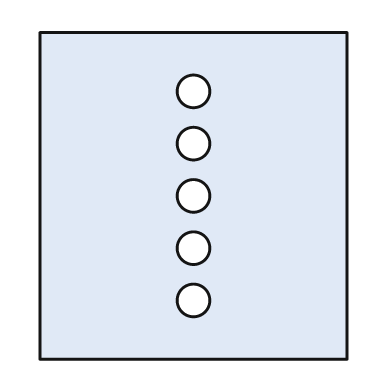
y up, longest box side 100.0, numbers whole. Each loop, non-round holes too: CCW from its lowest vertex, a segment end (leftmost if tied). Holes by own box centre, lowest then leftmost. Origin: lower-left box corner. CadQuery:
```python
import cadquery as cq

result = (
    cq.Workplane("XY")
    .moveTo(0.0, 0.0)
    .lineTo(94.0, 0.0)
    .lineTo(94.0, 100.0)
    .lineTo(0.0, 100.0)
    .close()
    .moveTo(47.0, 18.0)
    .circle(5.0)
    .moveTo(47.0, 34.0)
    .circle(5.0)
    .moveTo(47.0, 50.0)
    .circle(5.0)
    .moveTo(47.0, 66.0)
    .circle(5.0)
    .moveTo(47.0, 82.0)
    .circle(5.0)
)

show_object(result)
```